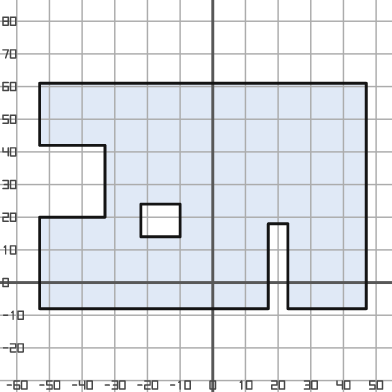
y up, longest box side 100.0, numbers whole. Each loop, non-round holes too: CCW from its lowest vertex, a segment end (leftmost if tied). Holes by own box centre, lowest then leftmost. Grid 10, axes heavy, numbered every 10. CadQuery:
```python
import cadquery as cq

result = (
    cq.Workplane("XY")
    .moveTo(-53.0, -8.0)
    .lineTo(17.0, -8.0)
    .lineTo(17.0, 18.0)
    .lineTo(23.0, 18.0)
    .lineTo(23.0, -8.0)
    .lineTo(47.0, -8.0)
    .lineTo(47.0, 61.0)
    .lineTo(-53.0, 61.0)
    .lineTo(-53.0, 42.0)
    .lineTo(-33.0, 42.0)
    .lineTo(-33.0, 20.0)
    .lineTo(-53.0, 20.0)
    .close()
    .moveTo(-22.0, 14.0)
    .lineTo(-10.0, 14.0)
    .lineTo(-10.0, 24.0)
    .lineTo(-22.0, 24.0)
    .close()
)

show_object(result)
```